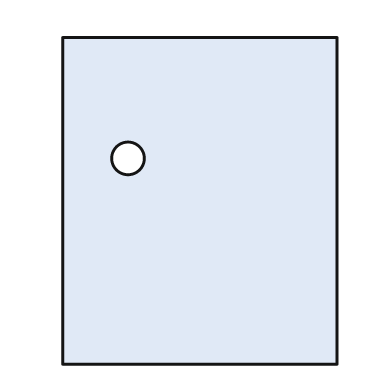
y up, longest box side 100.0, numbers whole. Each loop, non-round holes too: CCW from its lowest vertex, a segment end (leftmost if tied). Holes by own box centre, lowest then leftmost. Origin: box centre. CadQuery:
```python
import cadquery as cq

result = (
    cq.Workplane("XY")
    .moveTo(-42.0, -50.0)
    .lineTo(42.0, -50.0)
    .lineTo(42.0, 50.0)
    .lineTo(-42.0, 50.0)
    .close()
    .moveTo(-22.0, 13.0)
    .circle(5.0)
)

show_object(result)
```